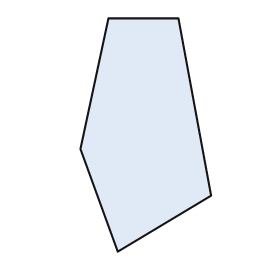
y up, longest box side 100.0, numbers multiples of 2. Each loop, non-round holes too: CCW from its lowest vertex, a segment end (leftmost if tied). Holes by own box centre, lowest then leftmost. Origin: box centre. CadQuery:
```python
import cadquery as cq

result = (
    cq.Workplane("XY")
    .moveTo(-12.0, -50.0)
    .lineTo(28.0, -26.0)
    .lineTo(14.0, 50.0)
    .lineTo(-16.0, 50.0)
    .lineTo(-28.0, -6.0)
    .close()
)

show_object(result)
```